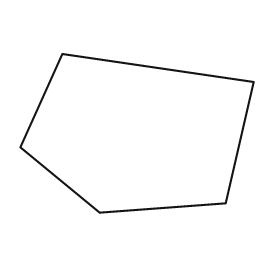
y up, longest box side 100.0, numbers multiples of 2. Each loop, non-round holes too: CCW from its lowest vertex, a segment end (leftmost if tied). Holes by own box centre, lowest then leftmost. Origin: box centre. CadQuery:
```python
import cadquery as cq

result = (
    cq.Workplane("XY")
    .moveTo(-16.0, -34.0)
    .lineTo(38.0, -30.0)
    .lineTo(50.0, 22.0)
    .lineTo(-32.0, 34.0)
    .lineTo(-50.0, -6.0)
    .close()
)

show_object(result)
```